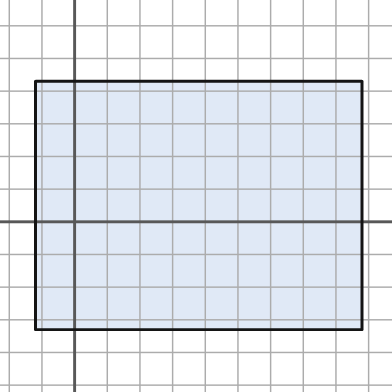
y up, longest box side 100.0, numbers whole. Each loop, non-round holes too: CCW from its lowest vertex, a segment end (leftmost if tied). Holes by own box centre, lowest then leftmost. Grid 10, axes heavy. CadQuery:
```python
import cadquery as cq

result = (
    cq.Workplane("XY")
    .moveTo(-12.0, -33.0)
    .lineTo(88.0, -33.0)
    .lineTo(88.0, 43.0)
    .lineTo(-12.0, 43.0)
    .close()
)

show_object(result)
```